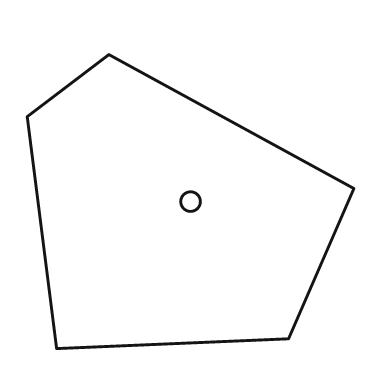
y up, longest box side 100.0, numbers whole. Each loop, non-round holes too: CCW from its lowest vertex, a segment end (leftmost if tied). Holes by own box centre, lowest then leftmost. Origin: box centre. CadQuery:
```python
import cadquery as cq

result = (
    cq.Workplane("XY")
    .moveTo(-41.0, -45.0)
    .lineTo(30.0, -42.0)
    .lineTo(50.0, 4.0)
    .lineTo(-25.0, 45.0)
    .lineTo(-50.0, 26.0)
    .close()
    .moveTo(0.0, 0.0)
    .circle(3.0)
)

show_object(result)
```